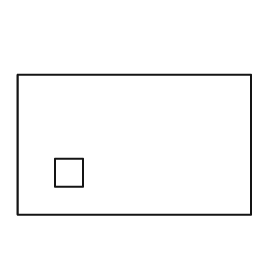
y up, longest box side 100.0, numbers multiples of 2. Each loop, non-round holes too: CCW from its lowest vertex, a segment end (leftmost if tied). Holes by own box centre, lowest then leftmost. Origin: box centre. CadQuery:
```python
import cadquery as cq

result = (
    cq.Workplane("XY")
    .moveTo(-50.0, -30.0)
    .lineTo(50.0, -30.0)
    .lineTo(50.0, 30.0)
    .lineTo(-50.0, 30.0)
    .close()
    .moveTo(-34.0, -18.0)
    .lineTo(-22.0, -18.0)
    .lineTo(-22.0, -6.0)
    .lineTo(-34.0, -6.0)
    .close()
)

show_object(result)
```